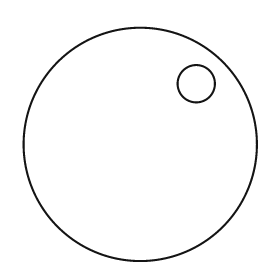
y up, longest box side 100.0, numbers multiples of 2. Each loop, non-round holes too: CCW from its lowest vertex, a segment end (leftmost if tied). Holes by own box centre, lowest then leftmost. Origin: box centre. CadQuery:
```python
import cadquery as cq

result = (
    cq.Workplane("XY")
    .moveTo(0.0, 0.0)
    .circle(50.0)
    .moveTo(24.0, 26.0)
    .circle(8.0)
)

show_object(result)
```